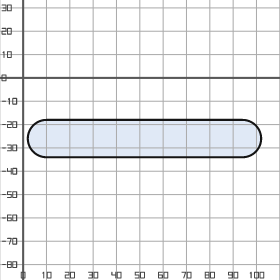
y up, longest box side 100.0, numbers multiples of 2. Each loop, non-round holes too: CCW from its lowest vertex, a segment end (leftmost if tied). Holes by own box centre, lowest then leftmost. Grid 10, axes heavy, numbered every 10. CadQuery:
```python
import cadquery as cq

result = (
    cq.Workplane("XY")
    .moveTo(10.0, -34.0)
    .lineTo(94.0, -34.0)
    .threePointArc((102.0, -26.0), (94.0, -18.0))
    .lineTo(10.0, -18.0)
    .threePointArc((2.0, -26.0), (10.0, -34.0))
    .close()
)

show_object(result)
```